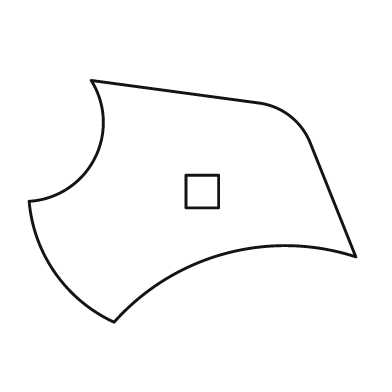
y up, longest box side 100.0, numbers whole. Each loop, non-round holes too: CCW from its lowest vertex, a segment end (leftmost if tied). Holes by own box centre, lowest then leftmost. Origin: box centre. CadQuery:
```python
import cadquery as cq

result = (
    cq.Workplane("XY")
    .moveTo(-24.0, -37.0)
    .threePointArc((10.0, -16.0), (50.0, -17.0))
    .lineTo(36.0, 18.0)
    .threePointArc((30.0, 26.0), (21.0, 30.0))
    .lineTo(-31.0, 37.0)
    .threePointArc((-30.0, 13.0), (-50.0, 0.0))
    .threePointArc((-42.0, -22.0), (-24.0, -37.0))
    .close()
    .moveTo(-2.0, -2.0)
    .lineTo(8.0, -2.0)
    .lineTo(8.0, 8.0)
    .lineTo(-2.0, 8.0)
    .close()
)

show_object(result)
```